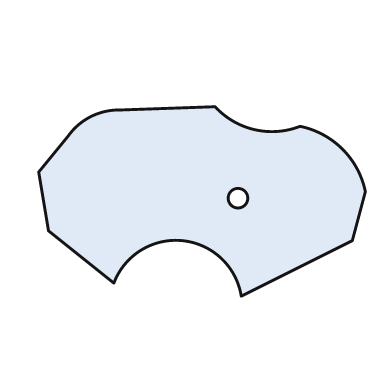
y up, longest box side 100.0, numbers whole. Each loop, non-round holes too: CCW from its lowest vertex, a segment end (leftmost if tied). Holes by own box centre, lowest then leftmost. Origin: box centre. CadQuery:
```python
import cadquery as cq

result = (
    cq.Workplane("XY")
    .moveTo(12.0, -29.0)
    .lineTo(46.0, -12.0)
    .lineTo(50.0, 3.0)
    .threePointArc((43.0, 16.0), (30.0, 23.0))
    .threePointArc((16.0, 22.0), (4.0, 29.0))
    .lineTo(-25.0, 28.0)
    .threePointArc((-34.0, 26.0), (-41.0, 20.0))
    .lineTo(-50.0, 9.0)
    .lineTo(-47.0, -9.0)
    .lineTo(-27.0, -25.0)
    .threePointArc((-6.0, -12.0), (12.0, -29.0))
    .close()
    .moveTo(11.0, 1.0)
    .circle(3.0)
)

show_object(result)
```